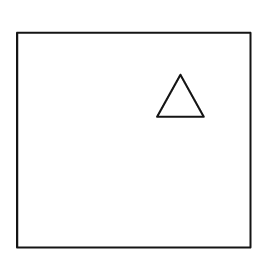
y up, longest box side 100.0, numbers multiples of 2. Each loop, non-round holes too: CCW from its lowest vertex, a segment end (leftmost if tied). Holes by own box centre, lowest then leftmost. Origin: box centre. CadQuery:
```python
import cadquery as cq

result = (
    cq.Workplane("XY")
    .moveTo(-50.0, -46.0)
    .lineTo(50.0, -46.0)
    .lineTo(50.0, 46.0)
    .lineTo(-50.0, 46.0)
    .close()
    .moveTo(10.0, 10.0)
    .lineTo(30.0, 10.0)
    .lineTo(20.0, 28.0)
    .close()
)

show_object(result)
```